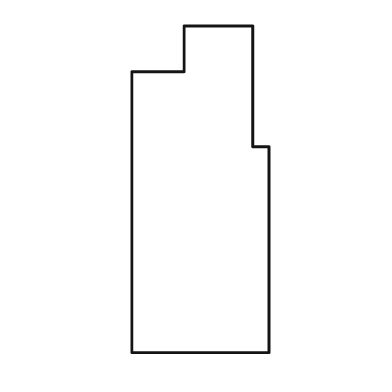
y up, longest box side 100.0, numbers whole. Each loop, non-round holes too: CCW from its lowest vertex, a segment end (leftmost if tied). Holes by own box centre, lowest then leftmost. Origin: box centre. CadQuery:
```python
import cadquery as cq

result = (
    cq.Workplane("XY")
    .moveTo(-21.0, -50.0)
    .lineTo(21.0, -50.0)
    .lineTo(21.0, 13.0)
    .lineTo(16.0, 13.0)
    .lineTo(16.0, 50.0)
    .lineTo(-5.0, 50.0)
    .lineTo(-5.0, 36.0)
    .lineTo(-21.0, 36.0)
    .close()
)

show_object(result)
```